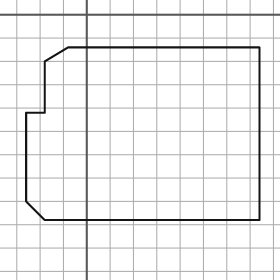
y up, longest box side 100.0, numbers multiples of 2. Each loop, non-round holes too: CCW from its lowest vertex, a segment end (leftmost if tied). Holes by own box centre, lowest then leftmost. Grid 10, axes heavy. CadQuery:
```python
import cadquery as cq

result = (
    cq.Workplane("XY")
    .moveTo(-18.0, -88.0)
    .lineTo(74.0, -88.0)
    .lineTo(74.0, -14.0)
    .lineTo(-8.0, -14.0)
    .lineTo(-18.0, -20.0)
    .lineTo(-18.0, -42.0)
    .lineTo(-26.0, -42.0)
    .lineTo(-26.0, -80.0)
    .close()
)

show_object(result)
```